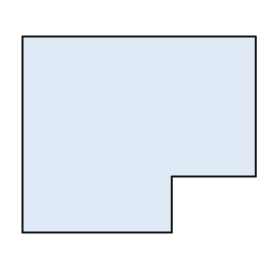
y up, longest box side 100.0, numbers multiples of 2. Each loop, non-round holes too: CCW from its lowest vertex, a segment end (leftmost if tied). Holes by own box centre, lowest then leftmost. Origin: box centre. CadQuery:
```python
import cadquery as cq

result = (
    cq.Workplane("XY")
    .moveTo(-50.0, -42.0)
    .lineTo(14.0, -42.0)
    .lineTo(14.0, -18.0)
    .lineTo(50.0, -18.0)
    .lineTo(50.0, 42.0)
    .lineTo(-50.0, 42.0)
    .close()
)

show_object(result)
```